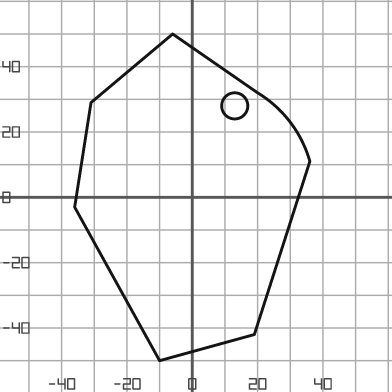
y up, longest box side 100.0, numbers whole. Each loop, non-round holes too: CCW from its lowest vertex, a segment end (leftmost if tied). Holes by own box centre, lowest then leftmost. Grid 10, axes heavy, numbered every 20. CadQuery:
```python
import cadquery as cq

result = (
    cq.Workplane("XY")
    .moveTo(-10.0, -50.0)
    .lineTo(19.0, -42.0)
    .lineTo(36.0, 11.0)
    .threePointArc((30.0, 23.0), (20.0, 32.0))
    .lineTo(-6.0, 50.0)
    .lineTo(-31.0, 29.0)
    .lineTo(-36.0, -3.0)
    .close()
    .moveTo(13.0, 28.0)
    .circle(4.0)
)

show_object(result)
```